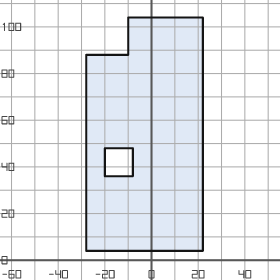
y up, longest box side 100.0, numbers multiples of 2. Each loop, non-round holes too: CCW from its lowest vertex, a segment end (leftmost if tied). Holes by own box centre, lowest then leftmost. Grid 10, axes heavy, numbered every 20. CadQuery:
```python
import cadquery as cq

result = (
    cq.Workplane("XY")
    .moveTo(-28.0, 4.0)
    .lineTo(22.0, 4.0)
    .lineTo(22.0, 104.0)
    .lineTo(-10.0, 104.0)
    .lineTo(-10.0, 88.0)
    .lineTo(-28.0, 88.0)
    .close()
    .moveTo(-20.0, 36.0)
    .lineTo(-8.0, 36.0)
    .lineTo(-8.0, 48.0)
    .lineTo(-20.0, 48.0)
    .close()
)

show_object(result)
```